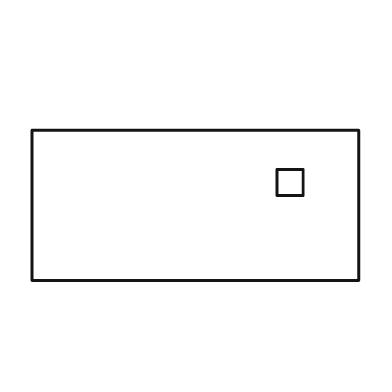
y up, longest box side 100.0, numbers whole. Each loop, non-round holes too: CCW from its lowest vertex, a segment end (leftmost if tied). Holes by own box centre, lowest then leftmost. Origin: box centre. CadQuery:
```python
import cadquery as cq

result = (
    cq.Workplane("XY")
    .moveTo(-50.0, -23.0)
    .lineTo(50.0, -23.0)
    .lineTo(50.0, 23.0)
    .lineTo(-50.0, 23.0)
    .close()
    .moveTo(25.0, 3.0)
    .lineTo(33.0, 3.0)
    .lineTo(33.0, 11.0)
    .lineTo(25.0, 11.0)
    .close()
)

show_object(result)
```